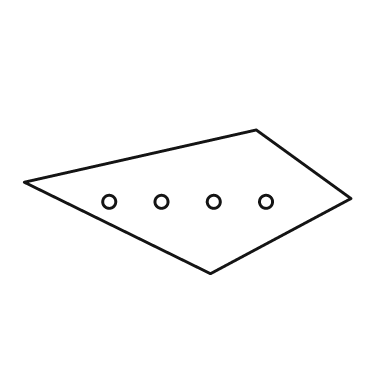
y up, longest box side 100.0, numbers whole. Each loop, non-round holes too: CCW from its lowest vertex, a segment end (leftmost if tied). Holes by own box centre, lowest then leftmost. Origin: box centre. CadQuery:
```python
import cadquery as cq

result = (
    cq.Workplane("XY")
    .moveTo(7.0, -22.0)
    .lineTo(50.0, 1.0)
    .lineTo(21.0, 22.0)
    .lineTo(-50.0, 6.0)
    .close()
    .moveTo(-24.0, 0.0)
    .circle(2.0)
    .moveTo(-8.0, 0.0)
    .circle(2.0)
    .moveTo(8.0, 0.0)
    .circle(2.0)
    .moveTo(24.0, 0.0)
    .circle(2.0)
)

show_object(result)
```